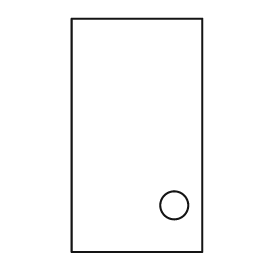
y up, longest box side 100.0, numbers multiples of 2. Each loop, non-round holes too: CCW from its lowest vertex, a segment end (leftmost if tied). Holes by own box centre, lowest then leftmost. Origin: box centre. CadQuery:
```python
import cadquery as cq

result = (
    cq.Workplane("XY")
    .moveTo(-28.0, -50.0)
    .lineTo(28.0, -50.0)
    .lineTo(28.0, 50.0)
    .lineTo(-28.0, 50.0)
    .close()
    .moveTo(16.0, -30.0)
    .circle(6.0)
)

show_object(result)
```